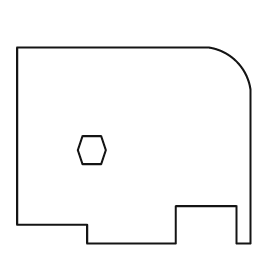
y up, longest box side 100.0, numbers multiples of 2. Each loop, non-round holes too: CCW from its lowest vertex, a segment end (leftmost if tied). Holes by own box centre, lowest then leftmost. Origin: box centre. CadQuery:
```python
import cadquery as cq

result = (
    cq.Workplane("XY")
    .moveTo(-20.0, -42.0)
    .lineTo(18.0, -42.0)
    .lineTo(18.0, -26.0)
    .lineTo(44.0, -26.0)
    .lineTo(44.0, -42.0)
    .lineTo(50.0, -42.0)
    .lineTo(50.0, 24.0)
    .threePointArc((44.0, 36.0), (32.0, 42.0))
    .lineTo(-50.0, 42.0)
    .lineTo(-50.0, -34.0)
    .lineTo(-20.0, -34.0)
    .close()
    .moveTo(-22.0, -8.0)
    .lineTo(-14.0, -8.0)
    .lineTo(-12.0, -2.0)
    .lineTo(-14.0, 4.0)
    .lineTo(-22.0, 4.0)
    .lineTo(-24.0, -2.0)
    .close()
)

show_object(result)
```